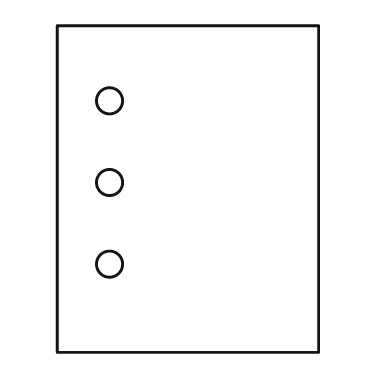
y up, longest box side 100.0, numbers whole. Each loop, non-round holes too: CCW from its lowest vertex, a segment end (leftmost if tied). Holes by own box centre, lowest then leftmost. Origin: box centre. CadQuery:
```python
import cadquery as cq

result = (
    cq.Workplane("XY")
    .moveTo(-40.0, -50.0)
    .lineTo(40.0, -50.0)
    .lineTo(40.0, 50.0)
    .lineTo(-40.0, 50.0)
    .close()
    .moveTo(-24.0, -23.0)
    .circle(4.0)
    .moveTo(-24.0, 2.0)
    .circle(4.0)
    .moveTo(-24.0, 27.0)
    .circle(4.0)
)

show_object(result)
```